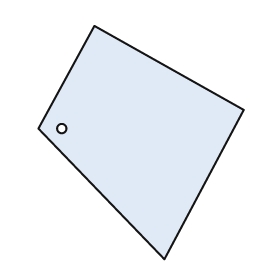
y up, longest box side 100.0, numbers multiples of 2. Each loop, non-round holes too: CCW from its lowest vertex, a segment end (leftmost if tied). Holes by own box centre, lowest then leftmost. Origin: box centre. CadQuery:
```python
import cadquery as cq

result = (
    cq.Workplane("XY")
    .moveTo(10.0, -50.0)
    .lineTo(44.0, 14.0)
    .lineTo(-20.0, 50.0)
    .lineTo(-44.0, 6.0)
    .close()
    .moveTo(-34.0, 6.0)
    .circle(2.0)
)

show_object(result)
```